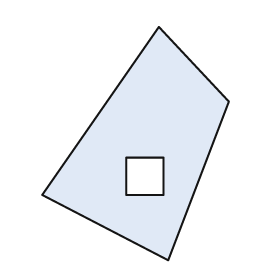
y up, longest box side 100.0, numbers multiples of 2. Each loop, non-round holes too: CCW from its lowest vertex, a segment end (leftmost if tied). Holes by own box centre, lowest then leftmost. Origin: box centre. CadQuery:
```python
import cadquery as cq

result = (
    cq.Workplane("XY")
    .moveTo(14.0, -50.0)
    .lineTo(40.0, 18.0)
    .lineTo(10.0, 50.0)
    .lineTo(-40.0, -22.0)
    .close()
    .moveTo(-4.0, -22.0)
    .lineTo(12.0, -22.0)
    .lineTo(12.0, -6.0)
    .lineTo(-4.0, -6.0)
    .close()
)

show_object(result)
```